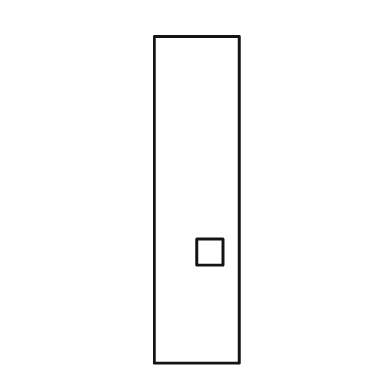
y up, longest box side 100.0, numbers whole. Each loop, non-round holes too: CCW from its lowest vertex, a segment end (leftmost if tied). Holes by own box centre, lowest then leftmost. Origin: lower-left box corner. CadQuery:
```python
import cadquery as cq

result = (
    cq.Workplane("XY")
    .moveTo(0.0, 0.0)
    .lineTo(26.0, 0.0)
    .lineTo(26.0, 100.0)
    .lineTo(0.0, 100.0)
    .close()
    .moveTo(13.0, 30.0)
    .lineTo(21.0, 30.0)
    .lineTo(21.0, 38.0)
    .lineTo(13.0, 38.0)
    .close()
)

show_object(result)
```